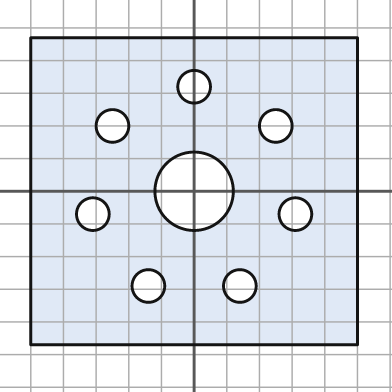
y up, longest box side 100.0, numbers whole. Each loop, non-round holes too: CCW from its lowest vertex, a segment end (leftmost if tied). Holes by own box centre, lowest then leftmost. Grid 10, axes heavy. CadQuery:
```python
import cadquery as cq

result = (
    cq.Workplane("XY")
    .moveTo(-50.0, -47.0)
    .lineTo(50.0, -47.0)
    .lineTo(50.0, 47.0)
    .lineTo(-50.0, 47.0)
    .close()
    .moveTo(-14.0, -29.0)
    .circle(5.0)
    .moveTo(14.0, -29.0)
    .circle(5.0)
    .moveTo(-31.0, -7.0)
    .circle(5.0)
    .moveTo(31.0, -7.0)
    .circle(5.0)
    .moveTo(0.0, 0.0)
    .circle(12.0)
    .moveTo(-25.0, 20.0)
    .circle(5.0)
    .moveTo(25.0, 20.0)
    .circle(5.0)
    .moveTo(0.0, 32.0)
    .circle(5.0)
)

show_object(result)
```